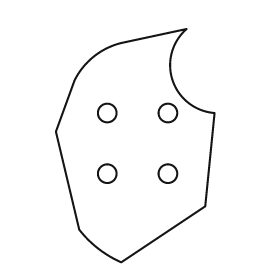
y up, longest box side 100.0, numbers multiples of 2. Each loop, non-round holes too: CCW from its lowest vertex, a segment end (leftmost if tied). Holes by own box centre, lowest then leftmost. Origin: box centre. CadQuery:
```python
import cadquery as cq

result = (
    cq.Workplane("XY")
    .moveTo(-6.0, -50.0)
    .lineTo(30.0, -26.0)
    .lineTo(34.0, 14.0)
    .threePointArc((16.0, 28.0), (22.0, 50.0))
    .lineTo(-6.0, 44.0)
    .threePointArc((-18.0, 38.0), (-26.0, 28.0))
    .lineTo(-34.0, 6.0)
    .lineTo(-24.0, -36.0)
    .threePointArc((-16.0, -44.0), (-6.0, -50.0))
    .close()
    .moveTo(-12.0, -12.0)
    .circle(4.0)
    .moveTo(14.0, -12.0)
    .circle(4.0)
    .moveTo(-12.0, 14.0)
    .circle(4.0)
    .moveTo(14.0, 14.0)
    .circle(4.0)
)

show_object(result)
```